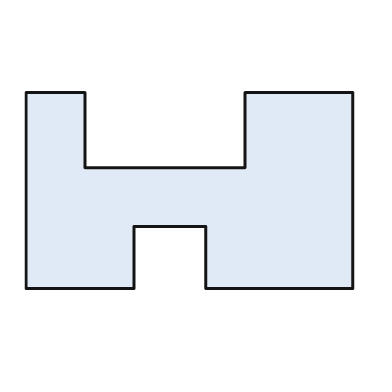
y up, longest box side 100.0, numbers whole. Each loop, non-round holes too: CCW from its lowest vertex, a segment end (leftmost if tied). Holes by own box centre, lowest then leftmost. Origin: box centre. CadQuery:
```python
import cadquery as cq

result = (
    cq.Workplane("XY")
    .moveTo(-50.0, -30.0)
    .lineTo(-17.0, -30.0)
    .lineTo(-17.0, -11.0)
    .lineTo(5.0, -11.0)
    .lineTo(5.0, -30.0)
    .lineTo(50.0, -30.0)
    .lineTo(50.0, 30.0)
    .lineTo(17.0, 30.0)
    .lineTo(17.0, 7.0)
    .lineTo(-32.0, 7.0)
    .lineTo(-32.0, 30.0)
    .lineTo(-50.0, 30.0)
    .close()
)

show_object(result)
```